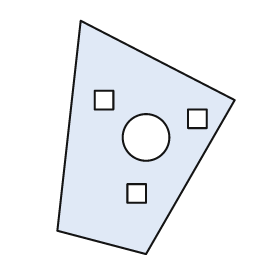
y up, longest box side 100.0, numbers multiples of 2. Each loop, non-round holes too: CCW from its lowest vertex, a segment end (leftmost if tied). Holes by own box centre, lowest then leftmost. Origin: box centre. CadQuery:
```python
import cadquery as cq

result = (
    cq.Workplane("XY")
    .moveTo(0.0, -50.0)
    .lineTo(38.0, 16.0)
    .lineTo(-28.0, 50.0)
    .lineTo(-38.0, -40.0)
    .close()
    .moveTo(-8.0, -28.0)
    .lineTo(0.0, -28.0)
    .lineTo(0.0, -20.0)
    .lineTo(-8.0, -20.0)
    .close()
    .moveTo(0.0, 0.0)
    .circle(10.0)
    .moveTo(18.0, 4.0)
    .lineTo(26.0, 4.0)
    .lineTo(26.0, 12.0)
    .lineTo(18.0, 12.0)
    .close()
    .moveTo(-22.0, 12.0)
    .lineTo(-14.0, 12.0)
    .lineTo(-14.0, 20.0)
    .lineTo(-22.0, 20.0)
    .close()
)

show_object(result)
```